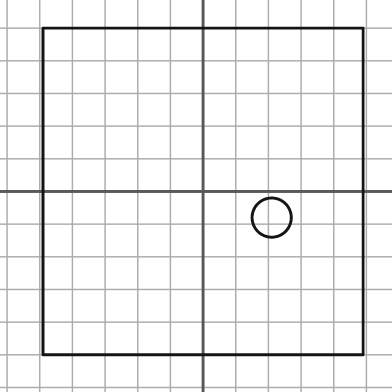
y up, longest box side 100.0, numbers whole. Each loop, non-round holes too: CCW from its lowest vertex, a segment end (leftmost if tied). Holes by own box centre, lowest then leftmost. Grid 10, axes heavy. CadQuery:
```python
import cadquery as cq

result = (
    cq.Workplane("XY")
    .moveTo(-49.0, -50.0)
    .lineTo(49.0, -50.0)
    .lineTo(49.0, 50.0)
    .lineTo(-49.0, 50.0)
    .close()
    .moveTo(21.0, -8.0)
    .circle(6.0)
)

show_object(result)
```